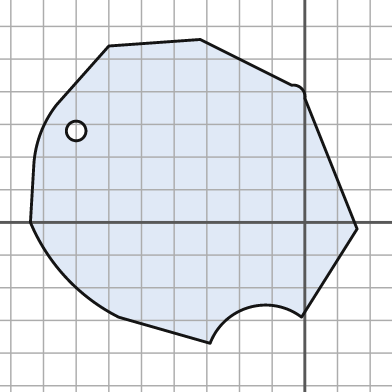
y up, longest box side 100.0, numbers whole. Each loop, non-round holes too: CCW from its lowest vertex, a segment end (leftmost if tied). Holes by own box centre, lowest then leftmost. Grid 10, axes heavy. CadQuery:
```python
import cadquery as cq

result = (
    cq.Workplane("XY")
    .moveTo(-29.0, -37.0)
    .threePointArc((-17.0, -26.0), (-1.0, -29.0))
    .lineTo(16.0, -2.0)
    .lineTo(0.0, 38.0)
    .threePointArc((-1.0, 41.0), (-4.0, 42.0))
    .lineTo(-32.0, 56.0)
    .lineTo(-60.0, 54.0)
    .lineTo(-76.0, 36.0)
    .threePointArc((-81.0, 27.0), (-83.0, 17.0))
    .lineTo(-84.0, 0.0)
    .threePointArc((-73.0, -17.0), (-57.0, -29.0))
    .close()
    .moveTo(-70.0, 28.0)
    .circle(3.0)
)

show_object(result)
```